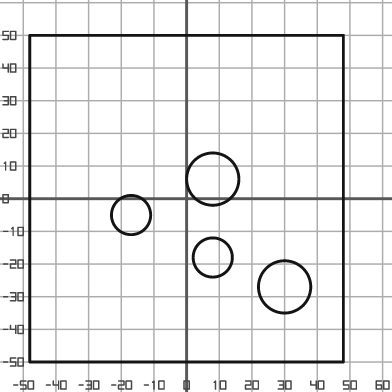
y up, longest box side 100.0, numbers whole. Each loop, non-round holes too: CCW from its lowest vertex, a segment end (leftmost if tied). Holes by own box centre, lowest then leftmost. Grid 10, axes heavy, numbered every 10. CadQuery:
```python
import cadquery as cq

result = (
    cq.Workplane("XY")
    .moveTo(-48.0, -50.0)
    .lineTo(48.0, -50.0)
    .lineTo(48.0, 50.0)
    .lineTo(-48.0, 50.0)
    .close()
    .moveTo(30.0, -27.0)
    .circle(8.0)
    .moveTo(8.0, -18.0)
    .circle(6.0)
    .moveTo(-17.0, -5.0)
    .circle(6.0)
    .moveTo(8.0, 6.0)
    .circle(8.0)
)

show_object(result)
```